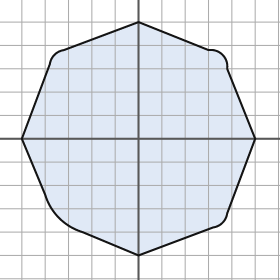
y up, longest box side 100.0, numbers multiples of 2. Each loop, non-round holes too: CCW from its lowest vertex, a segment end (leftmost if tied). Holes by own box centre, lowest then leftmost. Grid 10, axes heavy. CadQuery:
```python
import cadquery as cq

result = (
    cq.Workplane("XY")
    .moveTo(0.0, -50.0)
    .lineTo(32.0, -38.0)
    .threePointArc((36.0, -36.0), (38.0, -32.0))
    .lineTo(50.0, 0.0)
    .lineTo(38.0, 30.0)
    .threePointArc((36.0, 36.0), (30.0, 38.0))
    .lineTo(0.0, 50.0)
    .lineTo(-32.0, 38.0)
    .threePointArc((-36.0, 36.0), (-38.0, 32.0))
    .lineTo(-50.0, 0.0)
    .lineTo(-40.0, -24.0)
    .threePointArc((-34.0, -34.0), (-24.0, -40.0))
    .close()
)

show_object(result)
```